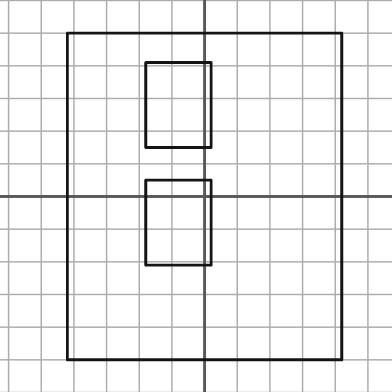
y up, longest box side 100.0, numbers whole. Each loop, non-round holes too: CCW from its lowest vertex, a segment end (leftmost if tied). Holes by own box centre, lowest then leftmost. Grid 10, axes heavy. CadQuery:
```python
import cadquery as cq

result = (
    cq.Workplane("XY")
    .moveTo(-42.0, -50.0)
    .lineTo(42.0, -50.0)
    .lineTo(42.0, 50.0)
    .lineTo(-42.0, 50.0)
    .close()
    .moveTo(-18.0, -21.0)
    .lineTo(2.0, -21.0)
    .lineTo(2.0, 5.0)
    .lineTo(-18.0, 5.0)
    .close()
    .moveTo(-18.0, 15.0)
    .lineTo(2.0, 15.0)
    .lineTo(2.0, 41.0)
    .lineTo(-18.0, 41.0)
    .close()
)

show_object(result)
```